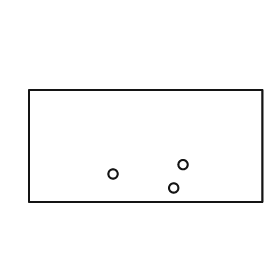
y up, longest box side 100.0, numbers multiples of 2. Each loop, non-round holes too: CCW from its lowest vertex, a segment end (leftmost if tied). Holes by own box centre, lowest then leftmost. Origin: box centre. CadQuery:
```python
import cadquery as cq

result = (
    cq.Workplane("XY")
    .moveTo(-50.0, -24.0)
    .lineTo(50.0, -24.0)
    .lineTo(50.0, 24.0)
    .lineTo(-50.0, 24.0)
    .close()
    .moveTo(12.0, -18.0)
    .circle(2.0)
    .moveTo(-14.0, -12.0)
    .circle(2.0)
    .moveTo(16.0, -8.0)
    .circle(2.0)
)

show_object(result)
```